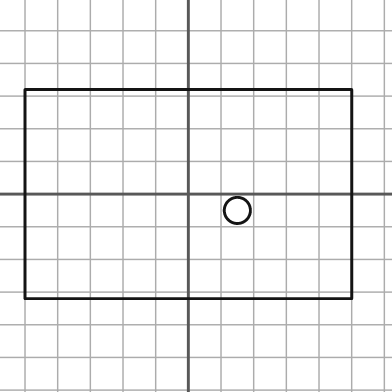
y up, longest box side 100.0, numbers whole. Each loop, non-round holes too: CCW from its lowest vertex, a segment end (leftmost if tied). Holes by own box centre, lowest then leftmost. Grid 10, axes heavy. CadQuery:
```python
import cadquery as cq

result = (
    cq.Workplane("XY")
    .moveTo(-50.0, -32.0)
    .lineTo(50.0, -32.0)
    .lineTo(50.0, 32.0)
    .lineTo(-50.0, 32.0)
    .close()
    .moveTo(15.0, -5.0)
    .circle(4.0)
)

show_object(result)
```